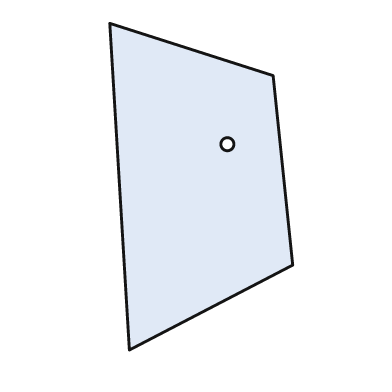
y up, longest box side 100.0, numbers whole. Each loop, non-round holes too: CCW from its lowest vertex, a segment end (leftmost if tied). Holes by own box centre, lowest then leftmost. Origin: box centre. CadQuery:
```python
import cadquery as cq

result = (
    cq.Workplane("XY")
    .moveTo(-22.0, -50.0)
    .lineTo(28.0, -24.0)
    .lineTo(22.0, 34.0)
    .lineTo(-28.0, 50.0)
    .close()
    .moveTo(8.0, 13.0)
    .circle(2.0)
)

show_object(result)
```